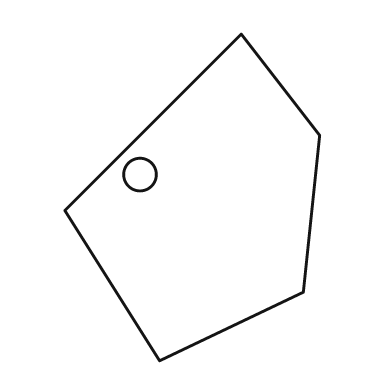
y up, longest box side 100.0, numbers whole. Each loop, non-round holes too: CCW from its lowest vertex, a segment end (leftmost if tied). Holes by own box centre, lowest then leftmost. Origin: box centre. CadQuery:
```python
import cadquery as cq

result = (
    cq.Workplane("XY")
    .moveTo(-10.0, -50.0)
    .lineTo(34.0, -29.0)
    .lineTo(39.0, 19.0)
    .lineTo(15.0, 50.0)
    .lineTo(-39.0, -4.0)
    .close()
    .moveTo(-16.0, 7.0)
    .circle(5.0)
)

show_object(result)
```